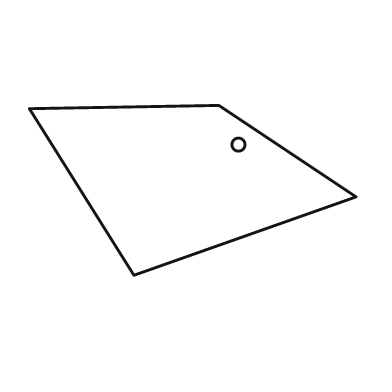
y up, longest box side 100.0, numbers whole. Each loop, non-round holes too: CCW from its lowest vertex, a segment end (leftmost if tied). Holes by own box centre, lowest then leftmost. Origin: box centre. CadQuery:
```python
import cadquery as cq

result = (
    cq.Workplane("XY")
    .moveTo(-18.0, -26.0)
    .lineTo(50.0, -2.0)
    .lineTo(8.0, 26.0)
    .lineTo(-50.0, 25.0)
    .close()
    .moveTo(14.0, 14.0)
    .circle(2.0)
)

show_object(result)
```